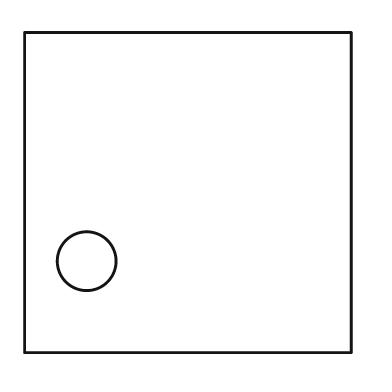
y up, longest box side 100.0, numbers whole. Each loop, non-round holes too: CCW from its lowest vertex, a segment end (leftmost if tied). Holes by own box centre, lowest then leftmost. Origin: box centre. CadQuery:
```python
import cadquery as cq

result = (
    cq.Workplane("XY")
    .moveTo(-50.0, -49.0)
    .lineTo(50.0, -49.0)
    .lineTo(50.0, 49.0)
    .lineTo(-50.0, 49.0)
    .close()
    .moveTo(-31.0, -21.0)
    .circle(9.0)
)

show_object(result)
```